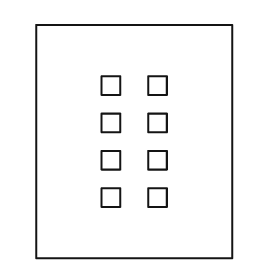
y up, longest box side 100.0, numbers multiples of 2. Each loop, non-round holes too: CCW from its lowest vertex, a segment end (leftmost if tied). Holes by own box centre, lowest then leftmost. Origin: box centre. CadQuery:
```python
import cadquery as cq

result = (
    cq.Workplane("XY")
    .moveTo(-42.0, -50.0)
    .lineTo(42.0, -50.0)
    .lineTo(42.0, 50.0)
    .lineTo(-42.0, 50.0)
    .close()
    .moveTo(-14.0, -28.0)
    .lineTo(-6.0, -28.0)
    .lineTo(-6.0, -20.0)
    .lineTo(-14.0, -20.0)
    .close()
    .moveTo(6.0, -28.0)
    .lineTo(14.0, -28.0)
    .lineTo(14.0, -20.0)
    .lineTo(6.0, -20.0)
    .close()
    .moveTo(-14.0, -12.0)
    .lineTo(-6.0, -12.0)
    .lineTo(-6.0, -4.0)
    .lineTo(-14.0, -4.0)
    .close()
    .moveTo(6.0, -12.0)
    .lineTo(14.0, -12.0)
    .lineTo(14.0, -4.0)
    .lineTo(6.0, -4.0)
    .close()
    .moveTo(-14.0, 4.0)
    .lineTo(-6.0, 4.0)
    .lineTo(-6.0, 12.0)
    .lineTo(-14.0, 12.0)
    .close()
    .moveTo(6.0, 4.0)
    .lineTo(14.0, 4.0)
    .lineTo(14.0, 12.0)
    .lineTo(6.0, 12.0)
    .close()
    .moveTo(-14.0, 20.0)
    .lineTo(-6.0, 20.0)
    .lineTo(-6.0, 28.0)
    .lineTo(-14.0, 28.0)
    .close()
    .moveTo(6.0, 20.0)
    .lineTo(14.0, 20.0)
    .lineTo(14.0, 28.0)
    .lineTo(6.0, 28.0)
    .close()
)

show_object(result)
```